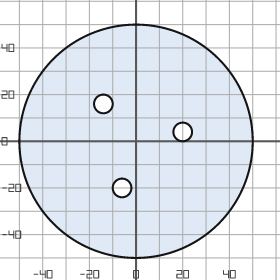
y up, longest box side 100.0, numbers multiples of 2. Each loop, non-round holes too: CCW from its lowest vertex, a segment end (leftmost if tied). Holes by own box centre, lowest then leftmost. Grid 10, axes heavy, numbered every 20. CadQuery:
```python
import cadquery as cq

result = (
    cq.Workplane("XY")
    .moveTo(0.0, 0.0)
    .circle(50.0)
    .moveTo(-6.0, -20.0)
    .circle(4.0)
    .moveTo(20.0, 4.0)
    .circle(4.0)
    .moveTo(-14.0, 16.0)
    .circle(4.0)
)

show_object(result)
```